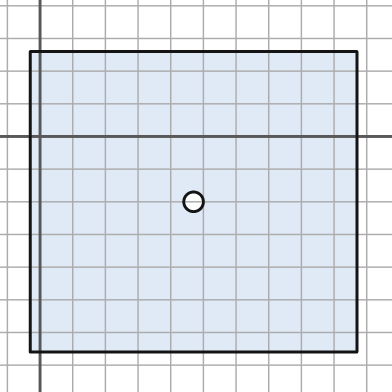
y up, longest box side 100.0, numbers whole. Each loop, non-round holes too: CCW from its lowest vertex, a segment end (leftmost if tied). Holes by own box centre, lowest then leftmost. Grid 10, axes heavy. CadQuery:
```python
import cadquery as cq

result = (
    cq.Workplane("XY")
    .moveTo(-3.0, -66.0)
    .lineTo(97.0, -66.0)
    .lineTo(97.0, 26.0)
    .lineTo(-3.0, 26.0)
    .close()
    .moveTo(47.0, -20.0)
    .circle(3.0)
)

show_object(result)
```